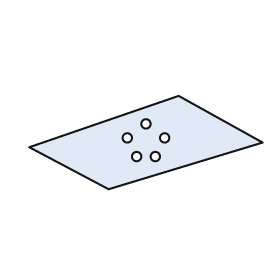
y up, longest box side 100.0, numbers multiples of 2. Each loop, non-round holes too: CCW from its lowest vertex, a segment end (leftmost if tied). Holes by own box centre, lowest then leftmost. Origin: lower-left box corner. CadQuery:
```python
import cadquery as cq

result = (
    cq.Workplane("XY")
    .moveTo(34.0, 0.0)
    .lineTo(100.0, 20.0)
    .lineTo(64.0, 40.0)
    .lineTo(0.0, 18.0)
    .close()
    .moveTo(46.0, 14.0)
    .circle(2.0)
    .moveTo(54.0, 14.0)
    .circle(2.0)
    .moveTo(42.0, 22.0)
    .circle(2.0)
    .moveTo(58.0, 22.0)
    .circle(2.0)
    .moveTo(50.0, 28.0)
    .circle(2.0)
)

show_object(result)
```